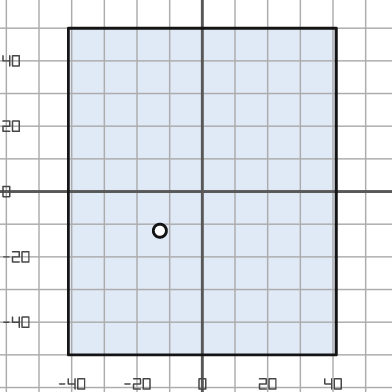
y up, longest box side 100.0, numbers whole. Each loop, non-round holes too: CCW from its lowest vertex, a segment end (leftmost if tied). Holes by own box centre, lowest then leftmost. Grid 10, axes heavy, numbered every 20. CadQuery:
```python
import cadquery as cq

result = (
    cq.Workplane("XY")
    .moveTo(-41.0, -50.0)
    .lineTo(41.0, -50.0)
    .lineTo(41.0, 50.0)
    .lineTo(-41.0, 50.0)
    .close()
    .moveTo(-13.0, -12.0)
    .circle(2.0)
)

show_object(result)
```